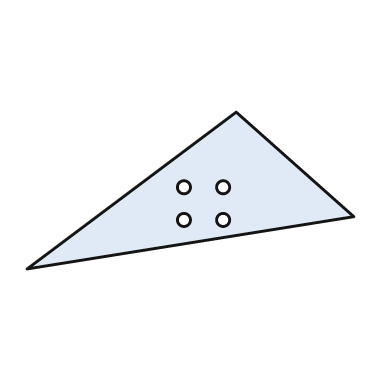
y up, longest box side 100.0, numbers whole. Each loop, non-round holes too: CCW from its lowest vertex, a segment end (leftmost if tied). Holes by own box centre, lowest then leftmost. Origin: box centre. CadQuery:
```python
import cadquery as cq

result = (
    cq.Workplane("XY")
    .moveTo(-50.0, -24.0)
    .lineTo(50.0, -8.0)
    .lineTo(14.0, 24.0)
    .close()
    .moveTo(-2.0, -9.0)
    .circle(2.0)
    .moveTo(10.0, -9.0)
    .circle(2.0)
    .moveTo(-2.0, 1.0)
    .circle(2.0)
    .moveTo(10.0, 1.0)
    .circle(2.0)
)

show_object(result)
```